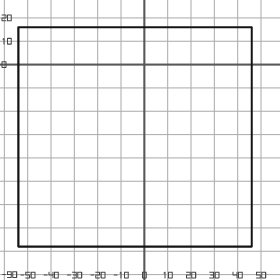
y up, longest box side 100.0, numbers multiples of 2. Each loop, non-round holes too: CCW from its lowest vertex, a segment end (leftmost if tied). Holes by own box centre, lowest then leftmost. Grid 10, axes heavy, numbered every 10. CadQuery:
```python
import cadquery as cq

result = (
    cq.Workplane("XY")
    .moveTo(-54.0, -78.0)
    .lineTo(46.0, -78.0)
    .lineTo(46.0, 16.0)
    .lineTo(-54.0, 16.0)
    .close()
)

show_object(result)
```